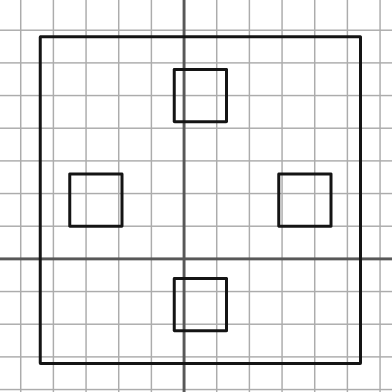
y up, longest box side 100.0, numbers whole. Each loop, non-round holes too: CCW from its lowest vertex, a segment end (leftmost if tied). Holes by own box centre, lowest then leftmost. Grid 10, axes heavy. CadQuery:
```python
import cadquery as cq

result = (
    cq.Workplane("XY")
    .moveTo(-44.0, -32.0)
    .lineTo(54.0, -32.0)
    .lineTo(54.0, 68.0)
    .lineTo(-44.0, 68.0)
    .close()
    .moveTo(-3.0, -22.0)
    .lineTo(13.0, -22.0)
    .lineTo(13.0, -6.0)
    .lineTo(-3.0, -6.0)
    .close()
    .moveTo(-35.0, 10.0)
    .lineTo(-19.0, 10.0)
    .lineTo(-19.0, 26.0)
    .lineTo(-35.0, 26.0)
    .close()
    .moveTo(29.0, 10.0)
    .lineTo(45.0, 10.0)
    .lineTo(45.0, 26.0)
    .lineTo(29.0, 26.0)
    .close()
    .moveTo(-3.0, 42.0)
    .lineTo(13.0, 42.0)
    .lineTo(13.0, 58.0)
    .lineTo(-3.0, 58.0)
    .close()
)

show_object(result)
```